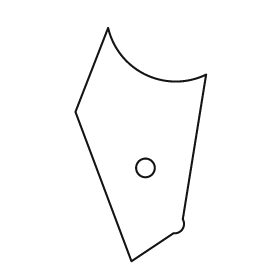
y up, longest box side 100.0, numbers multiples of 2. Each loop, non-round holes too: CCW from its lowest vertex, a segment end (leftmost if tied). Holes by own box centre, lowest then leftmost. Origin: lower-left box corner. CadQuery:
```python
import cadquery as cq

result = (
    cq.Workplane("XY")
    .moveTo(24.0, 0.0)
    .lineTo(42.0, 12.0)
    .threePointArc((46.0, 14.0), (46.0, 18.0))
    .lineTo(56.0, 80.0)
    .threePointArc((30.0, 80.0), (14.0, 100.0))
    .lineTo(0.0, 64.0)
    .close()
    .moveTo(30.0, 40.0)
    .circle(4.0)
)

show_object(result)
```